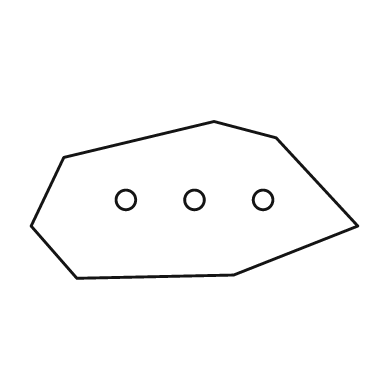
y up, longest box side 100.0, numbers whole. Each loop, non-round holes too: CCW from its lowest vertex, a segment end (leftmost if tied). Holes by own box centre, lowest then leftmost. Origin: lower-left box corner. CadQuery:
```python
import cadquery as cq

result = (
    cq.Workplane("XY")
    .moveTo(14.0, 0.0)
    .lineTo(62.0, 1.0)
    .lineTo(100.0, 16.0)
    .lineTo(75.0, 43.0)
    .lineTo(56.0, 48.0)
    .lineTo(10.0, 37.0)
    .lineTo(0.0, 16.0)
    .close()
    .moveTo(29.0, 24.0)
    .circle(3.0)
    .moveTo(50.0, 24.0)
    .circle(3.0)
    .moveTo(71.0, 24.0)
    .circle(3.0)
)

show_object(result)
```